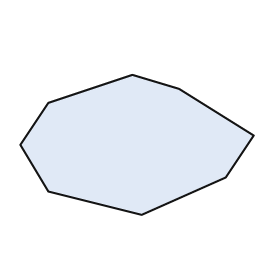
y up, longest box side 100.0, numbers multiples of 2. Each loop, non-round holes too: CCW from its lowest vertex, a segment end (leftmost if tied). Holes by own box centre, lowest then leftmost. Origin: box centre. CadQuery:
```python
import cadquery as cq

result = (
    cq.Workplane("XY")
    .moveTo(2.0, -30.0)
    .lineTo(38.0, -14.0)
    .lineTo(50.0, 4.0)
    .lineTo(18.0, 24.0)
    .lineTo(-2.0, 30.0)
    .lineTo(-38.0, 18.0)
    .lineTo(-50.0, 0.0)
    .lineTo(-38.0, -20.0)
    .close()
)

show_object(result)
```